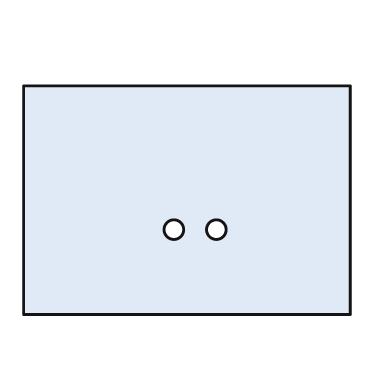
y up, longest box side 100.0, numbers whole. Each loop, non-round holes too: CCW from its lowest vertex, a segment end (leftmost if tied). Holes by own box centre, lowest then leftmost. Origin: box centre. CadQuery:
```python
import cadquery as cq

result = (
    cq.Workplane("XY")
    .moveTo(-50.0, -35.0)
    .lineTo(50.0, -35.0)
    .lineTo(50.0, 35.0)
    .lineTo(-50.0, 35.0)
    .close()
    .moveTo(-4.0, -9.0)
    .circle(3.0)
    .moveTo(9.0, -9.0)
    .circle(3.0)
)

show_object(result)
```